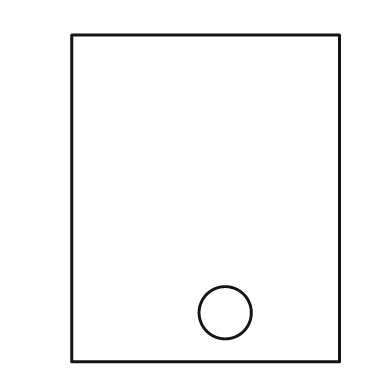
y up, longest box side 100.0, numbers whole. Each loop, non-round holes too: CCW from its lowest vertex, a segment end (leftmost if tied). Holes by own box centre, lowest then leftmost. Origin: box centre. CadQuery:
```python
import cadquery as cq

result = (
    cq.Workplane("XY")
    .moveTo(-41.0, -50.0)
    .lineTo(41.0, -50.0)
    .lineTo(41.0, 50.0)
    .lineTo(-41.0, 50.0)
    .close()
    .moveTo(6.0, -35.0)
    .circle(8.0)
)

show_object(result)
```